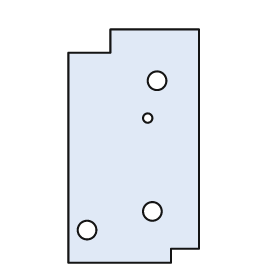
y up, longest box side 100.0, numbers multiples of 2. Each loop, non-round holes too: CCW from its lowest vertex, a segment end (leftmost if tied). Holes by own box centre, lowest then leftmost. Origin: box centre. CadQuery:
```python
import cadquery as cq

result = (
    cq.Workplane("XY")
    .moveTo(-28.0, -50.0)
    .lineTo(16.0, -50.0)
    .lineTo(16.0, -44.0)
    .lineTo(28.0, -44.0)
    .lineTo(28.0, 50.0)
    .lineTo(-10.0, 50.0)
    .lineTo(-10.0, 40.0)
    .lineTo(-28.0, 40.0)
    .close()
    .moveTo(-20.0, -36.0)
    .circle(4.0)
    .moveTo(8.0, -28.0)
    .circle(4.0)
    .moveTo(6.0, 12.0)
    .circle(2.0)
    .moveTo(10.0, 28.0)
    .circle(4.0)
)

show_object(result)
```